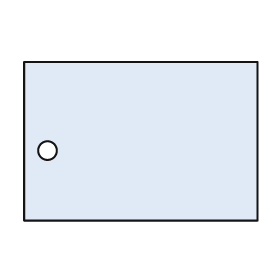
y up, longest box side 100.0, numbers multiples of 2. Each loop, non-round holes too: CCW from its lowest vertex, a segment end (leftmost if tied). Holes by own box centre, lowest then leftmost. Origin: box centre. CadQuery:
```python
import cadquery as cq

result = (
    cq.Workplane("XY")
    .moveTo(-50.0, -34.0)
    .lineTo(50.0, -34.0)
    .lineTo(50.0, 34.0)
    .lineTo(-50.0, 34.0)
    .close()
    .moveTo(-40.0, -4.0)
    .circle(4.0)
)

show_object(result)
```